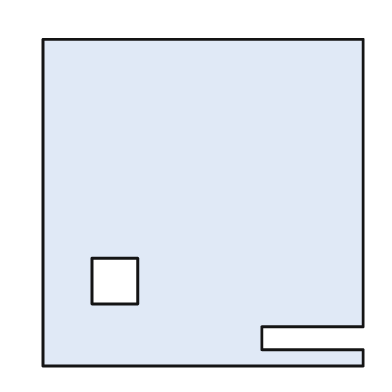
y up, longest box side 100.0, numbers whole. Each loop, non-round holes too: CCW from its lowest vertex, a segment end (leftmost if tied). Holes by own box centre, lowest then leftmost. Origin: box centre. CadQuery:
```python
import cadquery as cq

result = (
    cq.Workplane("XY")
    .moveTo(-49.0, -50.0)
    .lineTo(49.0, -50.0)
    .lineTo(49.0, -45.0)
    .lineTo(18.0, -45.0)
    .lineTo(18.0, -38.0)
    .lineTo(49.0, -38.0)
    .lineTo(49.0, 50.0)
    .lineTo(-49.0, 50.0)
    .close()
    .moveTo(-34.0, -31.0)
    .lineTo(-20.0, -31.0)
    .lineTo(-20.0, -17.0)
    .lineTo(-34.0, -17.0)
    .close()
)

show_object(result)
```